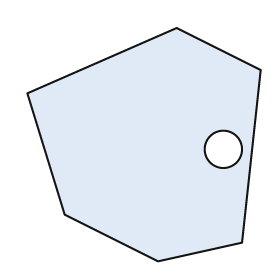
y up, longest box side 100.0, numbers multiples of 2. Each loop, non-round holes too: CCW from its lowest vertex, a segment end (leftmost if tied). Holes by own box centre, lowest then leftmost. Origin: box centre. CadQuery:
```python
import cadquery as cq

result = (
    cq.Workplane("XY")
    .moveTo(6.0, -50.0)
    .lineTo(42.0, -42.0)
    .lineTo(50.0, 32.0)
    .lineTo(14.0, 50.0)
    .lineTo(-50.0, 22.0)
    .lineTo(-34.0, -30.0)
    .close()
    .moveTo(34.0, -2.0)
    .circle(8.0)
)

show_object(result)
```